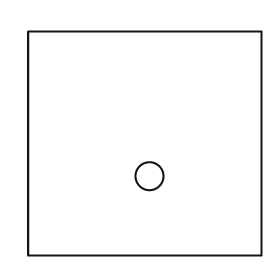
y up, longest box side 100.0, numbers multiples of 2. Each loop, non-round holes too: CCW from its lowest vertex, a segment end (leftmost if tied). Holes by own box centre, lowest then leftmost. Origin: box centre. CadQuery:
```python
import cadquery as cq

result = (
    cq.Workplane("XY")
    .moveTo(-50.0, -48.0)
    .lineTo(50.0, -48.0)
    .lineTo(50.0, 48.0)
    .lineTo(-50.0, 48.0)
    .close()
    .moveTo(2.0, -14.0)
    .circle(6.0)
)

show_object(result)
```